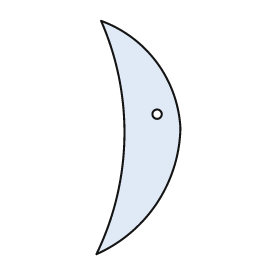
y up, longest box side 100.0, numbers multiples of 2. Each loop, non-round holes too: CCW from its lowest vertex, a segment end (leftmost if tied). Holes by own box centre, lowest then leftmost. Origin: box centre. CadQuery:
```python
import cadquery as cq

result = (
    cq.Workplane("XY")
    .moveTo(-18.0, -50.0)
    .threePointArc((8.0, -28.0), (18.0, 4.0))
    .threePointArc((8.0, 32.0), (-16.0, 50.0))
    .threePointArc((-6.0, 0.0), (-18.0, -50.0))
    .close()
    .moveTo(8.0, 10.0)
    .circle(2.0)
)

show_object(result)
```